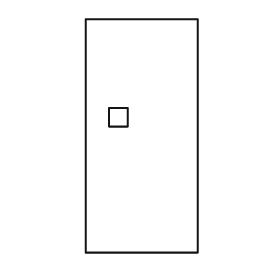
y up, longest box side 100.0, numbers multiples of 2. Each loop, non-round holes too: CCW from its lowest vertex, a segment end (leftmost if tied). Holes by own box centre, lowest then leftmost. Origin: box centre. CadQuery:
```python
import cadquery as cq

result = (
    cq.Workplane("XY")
    .moveTo(-24.0, -50.0)
    .lineTo(24.0, -50.0)
    .lineTo(24.0, 50.0)
    .lineTo(-24.0, 50.0)
    .close()
    .moveTo(-14.0, 4.0)
    .lineTo(-6.0, 4.0)
    .lineTo(-6.0, 12.0)
    .lineTo(-14.0, 12.0)
    .close()
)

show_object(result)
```